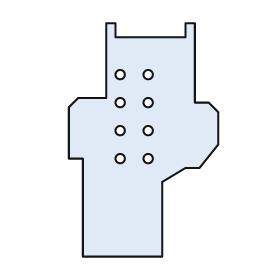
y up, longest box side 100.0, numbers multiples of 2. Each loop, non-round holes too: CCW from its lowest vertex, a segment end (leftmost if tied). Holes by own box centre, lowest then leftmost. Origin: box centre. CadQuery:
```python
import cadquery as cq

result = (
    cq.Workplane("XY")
    .moveTo(-26.0, -50.0)
    .lineTo(8.0, -50.0)
    .lineTo(8.0, -18.0)
    .lineTo(18.0, -12.0)
    .lineTo(24.0, -12.0)
    .lineTo(32.0, -2.0)
    .lineTo(32.0, 12.0)
    .lineTo(28.0, 16.0)
    .lineTo(22.0, 16.0)
    .lineTo(22.0, 50.0)
    .lineTo(18.0, 50.0)
    .lineTo(18.0, 44.0)
    .lineTo(-12.0, 44.0)
    .lineTo(-12.0, 50.0)
    .lineTo(-16.0, 50.0)
    .lineTo(-16.0, 18.0)
    .lineTo(-28.0, 18.0)
    .lineTo(-32.0, 14.0)
    .lineTo(-32.0, -8.0)
    .lineTo(-26.0, -8.0)
    .close()
    .moveTo(-10.0, -8.0)
    .circle(2.0)
    .moveTo(2.0, -8.0)
    .circle(2.0)
    .moveTo(-10.0, 4.0)
    .circle(2.0)
    .moveTo(2.0, 4.0)
    .circle(2.0)
    .moveTo(-10.0, 16.0)
    .circle(2.0)
    .moveTo(2.0, 16.0)
    .circle(2.0)
    .moveTo(-10.0, 28.0)
    .circle(2.0)
    .moveTo(2.0, 28.0)
    .circle(2.0)
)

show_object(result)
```